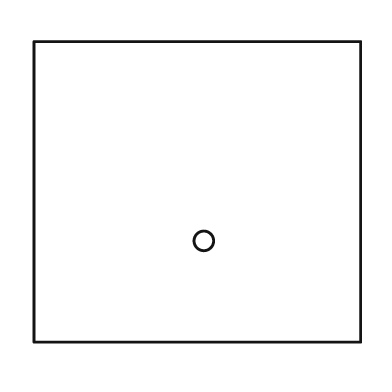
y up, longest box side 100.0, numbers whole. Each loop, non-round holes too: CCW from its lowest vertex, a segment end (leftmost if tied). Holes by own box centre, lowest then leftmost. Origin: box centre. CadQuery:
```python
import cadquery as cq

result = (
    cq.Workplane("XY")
    .moveTo(-50.0, -46.0)
    .lineTo(50.0, -46.0)
    .lineTo(50.0, 46.0)
    .lineTo(-50.0, 46.0)
    .close()
    .moveTo(2.0, -15.0)
    .circle(3.0)
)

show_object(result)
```